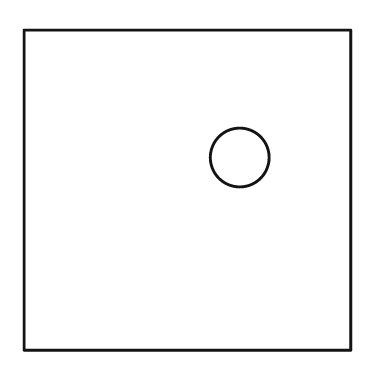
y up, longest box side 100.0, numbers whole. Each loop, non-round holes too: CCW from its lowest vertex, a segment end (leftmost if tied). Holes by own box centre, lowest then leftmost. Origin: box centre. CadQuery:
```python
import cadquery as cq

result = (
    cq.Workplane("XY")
    .moveTo(-50.0, -49.0)
    .lineTo(50.0, -49.0)
    .lineTo(50.0, 49.0)
    .lineTo(-50.0, 49.0)
    .close()
    .moveTo(16.0, 10.0)
    .circle(9.0)
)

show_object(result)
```